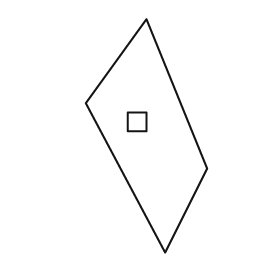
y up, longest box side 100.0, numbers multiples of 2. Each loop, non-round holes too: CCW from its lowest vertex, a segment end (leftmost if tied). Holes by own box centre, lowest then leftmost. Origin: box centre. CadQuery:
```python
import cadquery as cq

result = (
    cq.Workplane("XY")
    .moveTo(8.0, -50.0)
    .lineTo(26.0, -14.0)
    .lineTo(0.0, 50.0)
    .lineTo(-26.0, 14.0)
    .close()
    .moveTo(-8.0, 2.0)
    .lineTo(0.0, 2.0)
    .lineTo(0.0, 10.0)
    .lineTo(-8.0, 10.0)
    .close()
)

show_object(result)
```